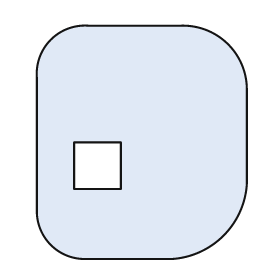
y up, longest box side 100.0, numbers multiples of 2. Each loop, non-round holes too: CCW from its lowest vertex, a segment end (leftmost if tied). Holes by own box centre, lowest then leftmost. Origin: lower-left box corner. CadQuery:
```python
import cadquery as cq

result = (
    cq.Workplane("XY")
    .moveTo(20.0, 0.0)
    .lineTo(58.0, 0.0)
    .threePointArc((80.0, 10.0), (90.0, 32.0))
    .lineTo(90.0, 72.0)
    .threePointArc((82.0, 92.0), (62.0, 100.0))
    .lineTo(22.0, 100.0)
    .threePointArc((6.0, 94.0), (0.0, 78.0))
    .lineTo(0.0, 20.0)
    .threePointArc((6.0, 6.0), (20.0, 0.0))
    .close()
    .moveTo(16.0, 30.0)
    .lineTo(36.0, 30.0)
    .lineTo(36.0, 50.0)
    .lineTo(16.0, 50.0)
    .close()
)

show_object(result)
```